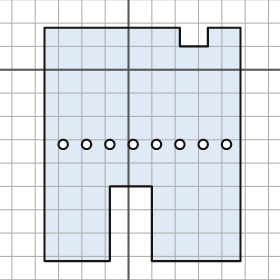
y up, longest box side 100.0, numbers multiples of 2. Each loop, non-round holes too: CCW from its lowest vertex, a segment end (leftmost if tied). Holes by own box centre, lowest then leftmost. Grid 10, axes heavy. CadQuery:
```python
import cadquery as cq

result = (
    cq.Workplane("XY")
    .moveTo(-36.0, -82.0)
    .lineTo(-8.0, -82.0)
    .lineTo(-8.0, -50.0)
    .lineTo(10.0, -50.0)
    .lineTo(10.0, -82.0)
    .lineTo(48.0, -82.0)
    .lineTo(48.0, 18.0)
    .lineTo(34.0, 18.0)
    .lineTo(34.0, 10.0)
    .lineTo(22.0, 10.0)
    .lineTo(22.0, 18.0)
    .lineTo(-36.0, 18.0)
    .close()
    .moveTo(-28.0, -32.0)
    .circle(2.0)
    .moveTo(-18.0, -32.0)
    .circle(2.0)
    .moveTo(-8.0, -32.0)
    .circle(2.0)
    .moveTo(2.0, -32.0)
    .circle(2.0)
    .moveTo(12.0, -32.0)
    .circle(2.0)
    .moveTo(22.0, -32.0)
    .circle(2.0)
    .moveTo(32.0, -32.0)
    .circle(2.0)
    .moveTo(42.0, -32.0)
    .circle(2.0)
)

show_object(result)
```